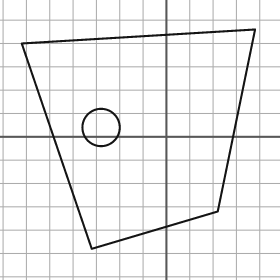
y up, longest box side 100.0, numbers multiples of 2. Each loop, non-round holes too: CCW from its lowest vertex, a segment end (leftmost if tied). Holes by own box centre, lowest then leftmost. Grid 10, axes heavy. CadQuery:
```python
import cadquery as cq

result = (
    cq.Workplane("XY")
    .moveTo(-32.0, -48.0)
    .lineTo(22.0, -32.0)
    .lineTo(38.0, 46.0)
    .lineTo(-62.0, 40.0)
    .close()
    .moveTo(-28.0, 4.0)
    .circle(8.0)
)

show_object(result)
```